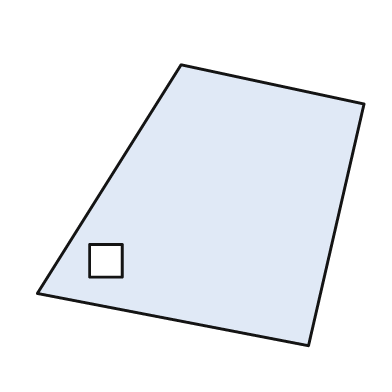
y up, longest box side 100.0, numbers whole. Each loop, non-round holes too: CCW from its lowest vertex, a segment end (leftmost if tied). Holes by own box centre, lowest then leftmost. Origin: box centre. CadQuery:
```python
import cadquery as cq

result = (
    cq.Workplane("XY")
    .moveTo(33.0, -43.0)
    .lineTo(50.0, 31.0)
    .lineTo(-6.0, 43.0)
    .lineTo(-50.0, -27.0)
    .close()
    .moveTo(-34.0, -22.0)
    .lineTo(-24.0, -22.0)
    .lineTo(-24.0, -12.0)
    .lineTo(-34.0, -12.0)
    .close()
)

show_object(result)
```